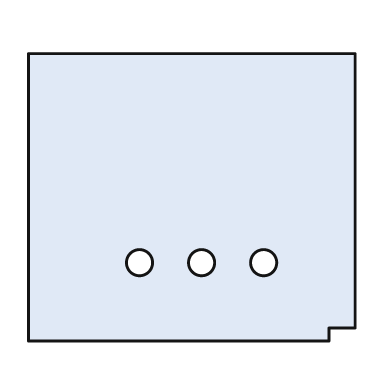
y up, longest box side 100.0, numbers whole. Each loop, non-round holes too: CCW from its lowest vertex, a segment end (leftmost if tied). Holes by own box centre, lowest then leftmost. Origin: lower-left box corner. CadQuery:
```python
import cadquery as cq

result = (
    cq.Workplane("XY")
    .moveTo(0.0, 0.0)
    .lineTo(92.0, 0.0)
    .lineTo(92.0, 4.0)
    .lineTo(100.0, 4.0)
    .lineTo(100.0, 88.0)
    .lineTo(0.0, 88.0)
    .close()
    .moveTo(34.0, 24.0)
    .circle(4.0)
    .moveTo(53.0, 24.0)
    .circle(4.0)
    .moveTo(72.0, 24.0)
    .circle(4.0)
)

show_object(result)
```